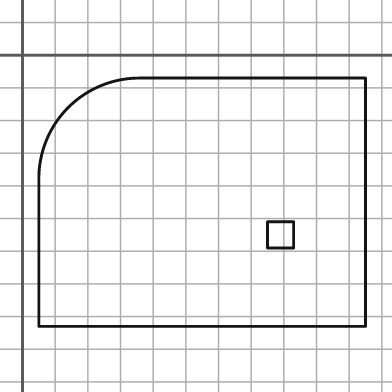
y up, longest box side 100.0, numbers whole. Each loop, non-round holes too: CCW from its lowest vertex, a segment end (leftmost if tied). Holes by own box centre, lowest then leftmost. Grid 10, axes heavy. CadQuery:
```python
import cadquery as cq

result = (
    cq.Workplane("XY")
    .moveTo(5.0, -83.0)
    .lineTo(105.0, -83.0)
    .lineTo(105.0, -7.0)
    .lineTo(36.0, -7.0)
    .threePointArc((14.0, -16.0), (5.0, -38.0))
    .close()
    .moveTo(75.0, -59.0)
    .lineTo(83.0, -59.0)
    .lineTo(83.0, -51.0)
    .lineTo(75.0, -51.0)
    .close()
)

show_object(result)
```